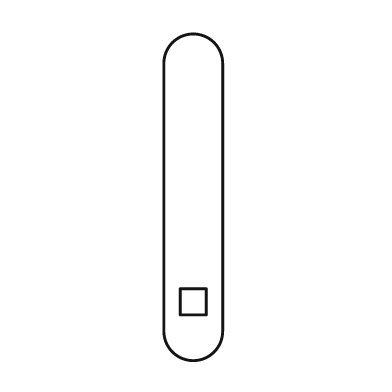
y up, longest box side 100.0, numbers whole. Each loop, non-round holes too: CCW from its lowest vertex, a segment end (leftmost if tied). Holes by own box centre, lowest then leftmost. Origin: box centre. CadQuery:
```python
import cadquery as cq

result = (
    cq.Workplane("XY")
    .moveTo(-9.0, -41.0)
    .threePointArc((0.0, -50.0), (9.0, -41.0))
    .lineTo(9.0, 41.0)
    .threePointArc((0.0, 50.0), (-9.0, 41.0))
    .close()
    .moveTo(-4.0, -36.0)
    .lineTo(4.0, -36.0)
    .lineTo(4.0, -28.0)
    .lineTo(-4.0, -28.0)
    .close()
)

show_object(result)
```